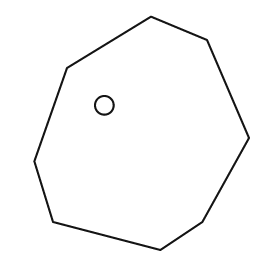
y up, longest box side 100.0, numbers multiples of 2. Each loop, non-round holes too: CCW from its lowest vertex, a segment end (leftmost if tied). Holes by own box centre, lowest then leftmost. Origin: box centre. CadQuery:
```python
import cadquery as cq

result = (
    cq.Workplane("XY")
    .moveTo(8.0, -50.0)
    .lineTo(26.0, -38.0)
    .lineTo(46.0, -2.0)
    .lineTo(28.0, 40.0)
    .lineTo(4.0, 50.0)
    .lineTo(-32.0, 28.0)
    .lineTo(-46.0, -12.0)
    .lineTo(-38.0, -38.0)
    .close()
    .moveTo(-16.0, 12.0)
    .circle(4.0)
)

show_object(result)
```